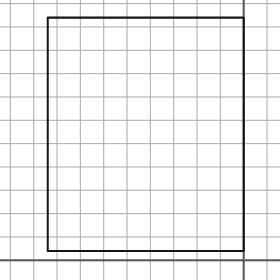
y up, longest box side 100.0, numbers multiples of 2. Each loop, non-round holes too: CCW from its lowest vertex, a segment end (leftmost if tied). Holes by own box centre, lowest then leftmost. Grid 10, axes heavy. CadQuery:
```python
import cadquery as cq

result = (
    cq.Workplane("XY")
    .moveTo(-84.0, 4.0)
    .lineTo(0.0, 4.0)
    .lineTo(0.0, 104.0)
    .lineTo(-84.0, 104.0)
    .close()
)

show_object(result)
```